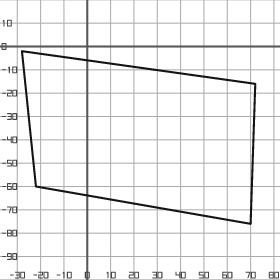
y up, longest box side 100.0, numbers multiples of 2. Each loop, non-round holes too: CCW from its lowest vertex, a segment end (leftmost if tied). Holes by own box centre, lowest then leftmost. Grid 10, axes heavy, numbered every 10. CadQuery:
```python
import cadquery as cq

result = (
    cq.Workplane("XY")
    .moveTo(70.0, -76.0)
    .lineTo(72.0, -16.0)
    .lineTo(-28.0, -2.0)
    .lineTo(-22.0, -60.0)
    .close()
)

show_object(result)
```